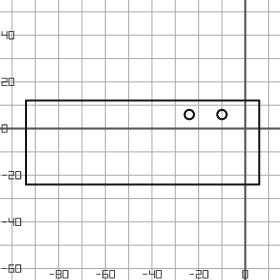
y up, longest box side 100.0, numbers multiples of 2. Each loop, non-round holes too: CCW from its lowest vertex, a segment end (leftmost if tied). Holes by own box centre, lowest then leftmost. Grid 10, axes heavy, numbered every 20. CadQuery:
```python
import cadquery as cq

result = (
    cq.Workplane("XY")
    .moveTo(-94.0, -24.0)
    .lineTo(6.0, -24.0)
    .lineTo(6.0, 12.0)
    .lineTo(-94.0, 12.0)
    .close()
    .moveTo(-24.0, 6.0)
    .circle(2.0)
    .moveTo(-10.0, 6.0)
    .circle(2.0)
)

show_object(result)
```